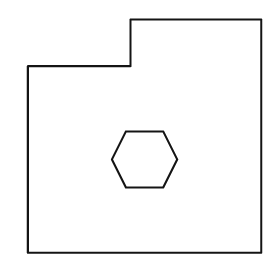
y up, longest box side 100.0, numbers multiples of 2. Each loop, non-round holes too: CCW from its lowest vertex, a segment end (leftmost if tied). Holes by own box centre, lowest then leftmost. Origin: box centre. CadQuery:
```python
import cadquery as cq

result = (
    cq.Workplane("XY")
    .moveTo(-50.0, -50.0)
    .lineTo(50.0, -50.0)
    .lineTo(50.0, 50.0)
    .lineTo(-6.0, 50.0)
    .lineTo(-6.0, 30.0)
    .lineTo(-50.0, 30.0)
    .close()
    .moveTo(-8.0, -22.0)
    .lineTo(8.0, -22.0)
    .lineTo(14.0, -10.0)
    .lineTo(8.0, 2.0)
    .lineTo(-8.0, 2.0)
    .lineTo(-14.0, -10.0)
    .close()
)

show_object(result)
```